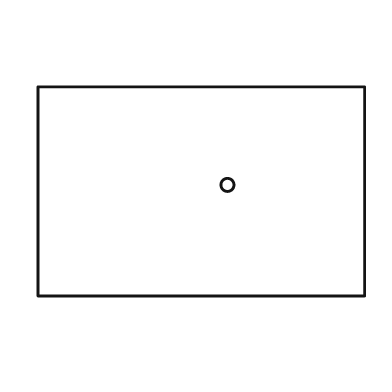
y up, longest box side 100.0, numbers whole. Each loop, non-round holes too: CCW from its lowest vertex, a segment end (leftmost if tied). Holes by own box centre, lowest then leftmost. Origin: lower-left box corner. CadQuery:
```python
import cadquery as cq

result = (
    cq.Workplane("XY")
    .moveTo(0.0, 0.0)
    .lineTo(100.0, 0.0)
    .lineTo(100.0, 64.0)
    .lineTo(0.0, 64.0)
    .close()
    .moveTo(58.0, 34.0)
    .circle(2.0)
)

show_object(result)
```